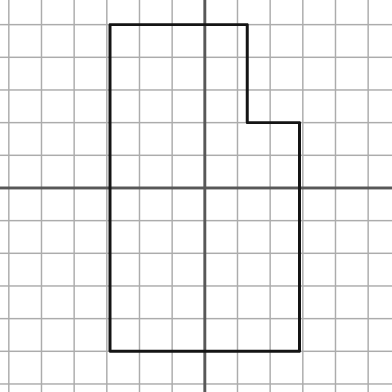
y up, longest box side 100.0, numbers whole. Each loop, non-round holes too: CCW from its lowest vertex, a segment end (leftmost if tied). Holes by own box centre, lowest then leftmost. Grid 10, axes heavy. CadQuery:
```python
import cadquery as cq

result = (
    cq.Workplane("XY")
    .moveTo(-29.0, -50.0)
    .lineTo(29.0, -50.0)
    .lineTo(29.0, 20.0)
    .lineTo(13.0, 20.0)
    .lineTo(13.0, 50.0)
    .lineTo(-29.0, 50.0)
    .close()
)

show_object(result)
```